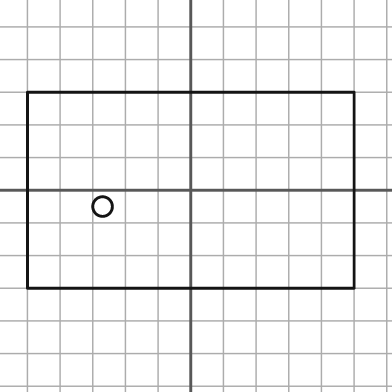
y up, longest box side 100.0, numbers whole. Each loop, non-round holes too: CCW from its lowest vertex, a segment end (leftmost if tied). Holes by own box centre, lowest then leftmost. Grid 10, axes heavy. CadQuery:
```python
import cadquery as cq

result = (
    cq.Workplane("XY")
    .moveTo(-50.0, -30.0)
    .lineTo(50.0, -30.0)
    .lineTo(50.0, 30.0)
    .lineTo(-50.0, 30.0)
    .close()
    .moveTo(-27.0, -5.0)
    .circle(3.0)
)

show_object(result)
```